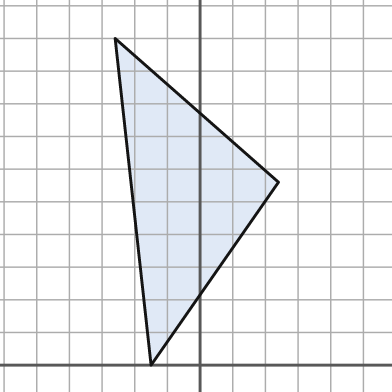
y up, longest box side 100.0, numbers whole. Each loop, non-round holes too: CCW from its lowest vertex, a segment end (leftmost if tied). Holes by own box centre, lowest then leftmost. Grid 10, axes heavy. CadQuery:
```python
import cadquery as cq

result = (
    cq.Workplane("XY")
    .moveTo(-15.0, 0.0)
    .lineTo(24.0, 56.0)
    .lineTo(-26.0, 100.0)
    .close()
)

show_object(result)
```